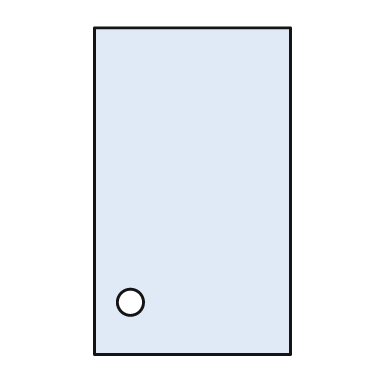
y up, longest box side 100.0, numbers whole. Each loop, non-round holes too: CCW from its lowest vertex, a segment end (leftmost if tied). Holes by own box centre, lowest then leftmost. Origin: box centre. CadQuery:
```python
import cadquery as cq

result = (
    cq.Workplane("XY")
    .moveTo(-30.0, -50.0)
    .lineTo(30.0, -50.0)
    .lineTo(30.0, 50.0)
    .lineTo(-30.0, 50.0)
    .close()
    .moveTo(-19.0, -34.0)
    .circle(4.0)
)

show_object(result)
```